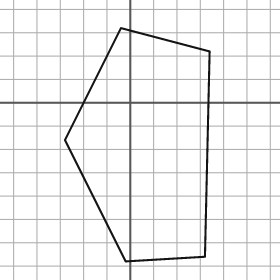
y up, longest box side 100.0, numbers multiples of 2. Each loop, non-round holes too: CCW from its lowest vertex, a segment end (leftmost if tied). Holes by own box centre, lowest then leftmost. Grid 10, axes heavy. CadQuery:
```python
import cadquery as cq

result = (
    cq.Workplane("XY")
    .moveTo(-2.0, -68.0)
    .lineTo(32.0, -66.0)
    .lineTo(34.0, 22.0)
    .lineTo(-4.0, 32.0)
    .lineTo(-28.0, -16.0)
    .close()
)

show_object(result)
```